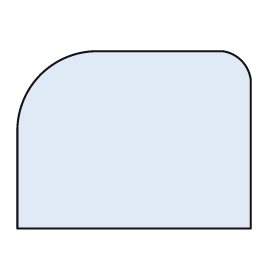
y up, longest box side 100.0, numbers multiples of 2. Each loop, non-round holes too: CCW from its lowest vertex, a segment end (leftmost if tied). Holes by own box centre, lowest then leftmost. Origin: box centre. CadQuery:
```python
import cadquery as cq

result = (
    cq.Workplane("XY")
    .moveTo(-50.0, -38.0)
    .lineTo(50.0, -38.0)
    .lineTo(50.0, 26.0)
    .threePointArc((46.0, 34.0), (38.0, 38.0))
    .lineTo(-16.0, 38.0)
    .threePointArc((-40.0, 28.0), (-50.0, 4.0))
    .close()
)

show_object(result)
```